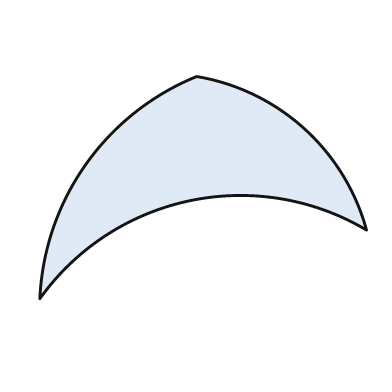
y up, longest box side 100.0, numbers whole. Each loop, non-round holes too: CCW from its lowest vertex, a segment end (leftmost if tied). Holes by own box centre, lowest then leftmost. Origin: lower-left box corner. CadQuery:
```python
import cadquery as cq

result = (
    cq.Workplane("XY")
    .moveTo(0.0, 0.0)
    .threePointArc((46.0, 30.0), (100.0, 21.0))
    .threePointArc((81.0, 52.0), (48.0, 68.0))
    .threePointArc((14.0, 41.0), (0.0, 0.0))
    .close()
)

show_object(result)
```